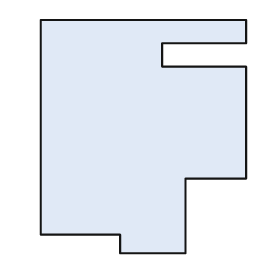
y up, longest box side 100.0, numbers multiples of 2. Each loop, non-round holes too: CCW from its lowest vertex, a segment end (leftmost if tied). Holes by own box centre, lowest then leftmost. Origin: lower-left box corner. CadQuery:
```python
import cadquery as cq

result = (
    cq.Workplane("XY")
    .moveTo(34.0, 0.0)
    .lineTo(62.0, 0.0)
    .lineTo(62.0, 32.0)
    .lineTo(88.0, 32.0)
    .lineTo(88.0, 80.0)
    .lineTo(52.0, 80.0)
    .lineTo(52.0, 90.0)
    .lineTo(88.0, 90.0)
    .lineTo(88.0, 100.0)
    .lineTo(0.0, 100.0)
    .lineTo(0.0, 8.0)
    .lineTo(34.0, 8.0)
    .close()
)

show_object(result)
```